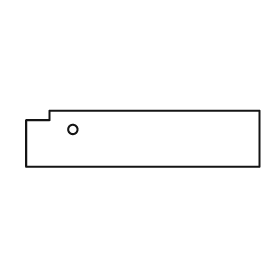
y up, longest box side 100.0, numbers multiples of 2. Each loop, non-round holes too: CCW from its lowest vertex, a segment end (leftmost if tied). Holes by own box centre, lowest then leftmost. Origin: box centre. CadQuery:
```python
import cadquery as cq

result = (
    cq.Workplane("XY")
    .moveTo(-50.0, -12.0)
    .lineTo(50.0, -12.0)
    .lineTo(50.0, 12.0)
    .lineTo(-40.0, 12.0)
    .lineTo(-40.0, 8.0)
    .lineTo(-50.0, 8.0)
    .close()
    .moveTo(-30.0, 4.0)
    .circle(2.0)
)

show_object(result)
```